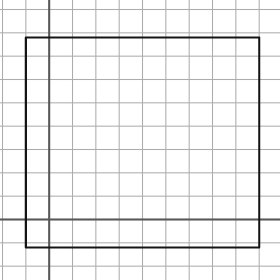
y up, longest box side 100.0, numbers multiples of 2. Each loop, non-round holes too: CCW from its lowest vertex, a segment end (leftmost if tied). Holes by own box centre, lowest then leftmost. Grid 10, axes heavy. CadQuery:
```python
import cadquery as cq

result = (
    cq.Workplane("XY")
    .moveTo(-10.0, -12.0)
    .lineTo(90.0, -12.0)
    .lineTo(90.0, 78.0)
    .lineTo(-10.0, 78.0)
    .close()
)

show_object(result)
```